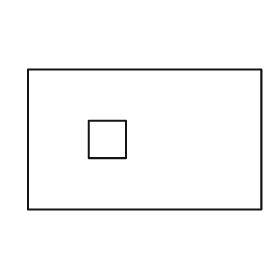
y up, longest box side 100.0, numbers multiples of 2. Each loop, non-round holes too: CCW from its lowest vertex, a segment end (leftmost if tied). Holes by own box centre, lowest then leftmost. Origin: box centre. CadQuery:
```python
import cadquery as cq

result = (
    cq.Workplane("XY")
    .moveTo(-50.0, -30.0)
    .lineTo(50.0, -30.0)
    .lineTo(50.0, 30.0)
    .lineTo(-50.0, 30.0)
    .close()
    .moveTo(-24.0, -8.0)
    .lineTo(-8.0, -8.0)
    .lineTo(-8.0, 8.0)
    .lineTo(-24.0, 8.0)
    .close()
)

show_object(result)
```